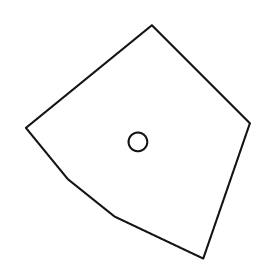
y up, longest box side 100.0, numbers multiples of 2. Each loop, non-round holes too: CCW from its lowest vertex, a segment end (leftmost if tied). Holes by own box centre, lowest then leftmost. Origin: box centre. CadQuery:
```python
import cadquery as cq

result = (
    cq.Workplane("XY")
    .moveTo(28.0, -50.0)
    .lineTo(48.0, 8.0)
    .lineTo(6.0, 50.0)
    .lineTo(-48.0, 6.0)
    .lineTo(-30.0, -16.0)
    .lineTo(-10.0, -32.0)
    .close()
    .moveTo(0.0, 0.0)
    .circle(4.0)
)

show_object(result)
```